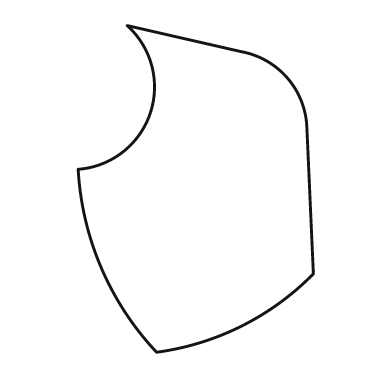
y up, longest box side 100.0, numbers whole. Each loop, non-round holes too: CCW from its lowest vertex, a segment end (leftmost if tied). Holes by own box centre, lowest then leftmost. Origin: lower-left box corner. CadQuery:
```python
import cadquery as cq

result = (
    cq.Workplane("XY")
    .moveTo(24.0, 0.0)
    .threePointArc((50.0, 8.0), (72.0, 24.0))
    .lineTo(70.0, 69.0)
    .threePointArc((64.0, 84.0), (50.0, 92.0))
    .lineTo(15.0, 100.0)
    .threePointArc((22.0, 73.0), (0.0, 56.0))
    .threePointArc((7.0, 26.0), (24.0, 0.0))
    .close()
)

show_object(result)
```